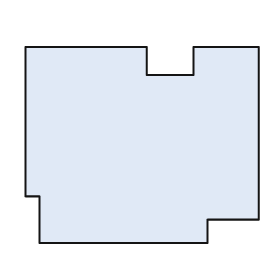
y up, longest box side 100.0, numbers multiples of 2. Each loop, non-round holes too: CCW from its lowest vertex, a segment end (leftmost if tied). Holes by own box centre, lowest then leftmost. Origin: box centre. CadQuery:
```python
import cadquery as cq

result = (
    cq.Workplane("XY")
    .moveTo(-44.0, -42.0)
    .lineTo(28.0, -42.0)
    .lineTo(28.0, -32.0)
    .lineTo(50.0, -32.0)
    .lineTo(50.0, 42.0)
    .lineTo(22.0, 42.0)
    .lineTo(22.0, 30.0)
    .lineTo(2.0, 30.0)
    .lineTo(2.0, 42.0)
    .lineTo(-50.0, 42.0)
    .lineTo(-50.0, -22.0)
    .lineTo(-44.0, -22.0)
    .close()
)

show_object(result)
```